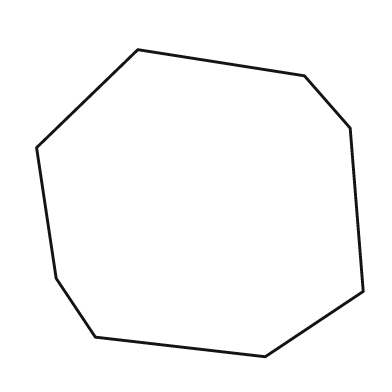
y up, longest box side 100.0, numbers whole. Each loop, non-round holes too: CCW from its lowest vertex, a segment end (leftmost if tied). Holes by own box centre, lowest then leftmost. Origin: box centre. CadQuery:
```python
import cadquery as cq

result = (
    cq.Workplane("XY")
    .moveTo(20.0, -47.0)
    .lineTo(50.0, -27.0)
    .lineTo(46.0, 23.0)
    .lineTo(32.0, 39.0)
    .lineTo(-19.0, 47.0)
    .lineTo(-50.0, 17.0)
    .lineTo(-44.0, -23.0)
    .lineTo(-32.0, -41.0)
    .close()
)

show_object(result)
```